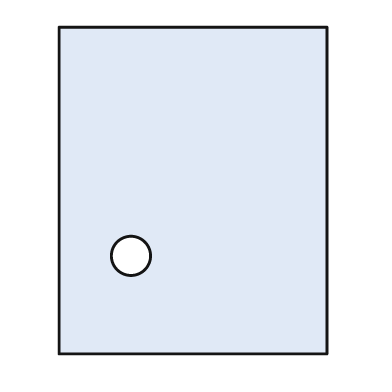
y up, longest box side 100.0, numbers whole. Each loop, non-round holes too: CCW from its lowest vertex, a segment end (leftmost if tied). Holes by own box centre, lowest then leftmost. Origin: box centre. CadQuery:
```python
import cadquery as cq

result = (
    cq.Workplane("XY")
    .moveTo(-41.0, -50.0)
    .lineTo(41.0, -50.0)
    .lineTo(41.0, 50.0)
    .lineTo(-41.0, 50.0)
    .close()
    .moveTo(-19.0, -20.0)
    .circle(6.0)
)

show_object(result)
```